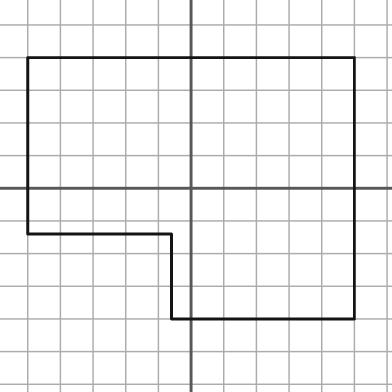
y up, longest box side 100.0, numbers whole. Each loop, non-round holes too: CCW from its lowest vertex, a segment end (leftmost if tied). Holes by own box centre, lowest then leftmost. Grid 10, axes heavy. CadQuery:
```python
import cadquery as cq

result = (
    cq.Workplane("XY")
    .moveTo(-6.0, -40.0)
    .lineTo(50.0, -40.0)
    .lineTo(50.0, 40.0)
    .lineTo(-50.0, 40.0)
    .lineTo(-50.0, -14.0)
    .lineTo(-6.0, -14.0)
    .close()
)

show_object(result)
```